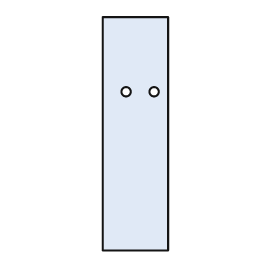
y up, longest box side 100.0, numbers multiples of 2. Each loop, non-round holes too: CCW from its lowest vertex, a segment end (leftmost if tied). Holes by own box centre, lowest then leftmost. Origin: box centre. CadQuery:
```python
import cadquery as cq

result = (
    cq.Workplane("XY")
    .moveTo(-14.0, -50.0)
    .lineTo(14.0, -50.0)
    .lineTo(14.0, 50.0)
    .lineTo(-14.0, 50.0)
    .close()
    .moveTo(-4.0, 18.0)
    .circle(2.0)
    .moveTo(8.0, 18.0)
    .circle(2.0)
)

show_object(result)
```